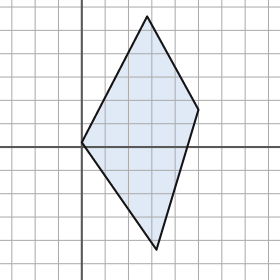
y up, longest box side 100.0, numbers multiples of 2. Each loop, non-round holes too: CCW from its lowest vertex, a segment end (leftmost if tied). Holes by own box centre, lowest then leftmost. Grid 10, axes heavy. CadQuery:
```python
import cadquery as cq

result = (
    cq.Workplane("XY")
    .moveTo(32.0, -44.0)
    .lineTo(50.0, 16.0)
    .lineTo(28.0, 56.0)
    .lineTo(0.0, 2.0)
    .close()
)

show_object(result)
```